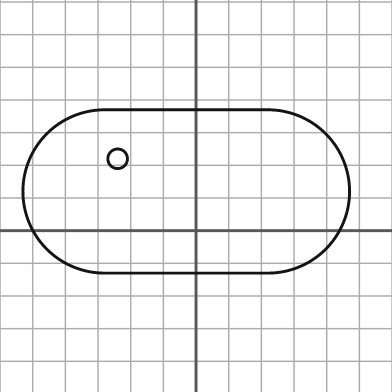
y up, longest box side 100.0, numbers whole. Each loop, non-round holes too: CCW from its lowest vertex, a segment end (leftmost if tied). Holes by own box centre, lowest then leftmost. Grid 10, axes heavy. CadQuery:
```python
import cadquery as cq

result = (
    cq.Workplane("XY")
    .moveTo(-28.0, -13.0)
    .lineTo(22.0, -13.0)
    .threePointArc((47.0, 12.0), (22.0, 37.0))
    .lineTo(-28.0, 37.0)
    .threePointArc((-53.0, 12.0), (-28.0, -13.0))
    .close()
    .moveTo(-24.0, 22.0)
    .circle(3.0)
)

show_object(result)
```